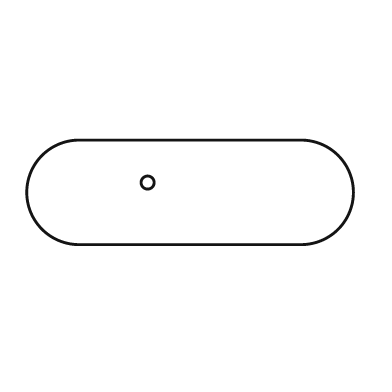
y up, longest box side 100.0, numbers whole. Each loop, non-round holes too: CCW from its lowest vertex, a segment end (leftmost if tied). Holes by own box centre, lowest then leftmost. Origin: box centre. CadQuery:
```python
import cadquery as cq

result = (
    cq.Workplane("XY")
    .moveTo(-34.0, -16.0)
    .lineTo(34.0, -16.0)
    .threePointArc((50.0, 0.0), (34.0, 16.0))
    .lineTo(-34.0, 16.0)
    .threePointArc((-50.0, 0.0), (-34.0, -16.0))
    .close()
    .moveTo(-13.0, 3.0)
    .circle(2.0)
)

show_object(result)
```